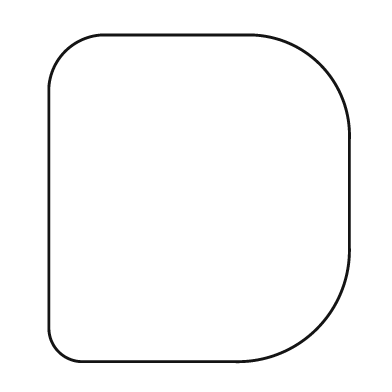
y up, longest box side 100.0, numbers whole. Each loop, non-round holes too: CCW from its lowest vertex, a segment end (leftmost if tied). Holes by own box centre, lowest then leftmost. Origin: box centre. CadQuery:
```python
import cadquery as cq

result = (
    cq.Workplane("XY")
    .moveTo(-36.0, -50.0)
    .lineTo(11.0, -50.0)
    .threePointArc((36.0, -40.0), (46.0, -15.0))
    .lineTo(46.0, 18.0)
    .threePointArc((37.0, 41.0), (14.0, 50.0))
    .lineTo(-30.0, 50.0)
    .threePointArc((-41.0, 45.0), (-46.0, 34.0))
    .lineTo(-46.0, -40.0)
    .threePointArc((-43.0, -47.0), (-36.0, -50.0))
    .close()
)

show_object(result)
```